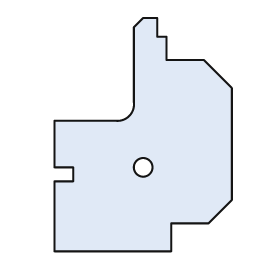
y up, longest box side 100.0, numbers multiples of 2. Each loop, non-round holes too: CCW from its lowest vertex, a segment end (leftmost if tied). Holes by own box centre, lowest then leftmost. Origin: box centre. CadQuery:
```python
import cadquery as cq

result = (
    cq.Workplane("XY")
    .moveTo(-38.0, -50.0)
    .lineTo(12.0, -50.0)
    .lineTo(12.0, -38.0)
    .lineTo(28.0, -38.0)
    .lineTo(38.0, -28.0)
    .lineTo(38.0, 20.0)
    .lineTo(26.0, 32.0)
    .lineTo(10.0, 32.0)
    .lineTo(10.0, 42.0)
    .lineTo(6.0, 42.0)
    .lineTo(6.0, 50.0)
    .lineTo(0.0, 50.0)
    .lineTo(-4.0, 46.0)
    .lineTo(-4.0, 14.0)
    .threePointArc((-6.0, 8.0), (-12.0, 6.0))
    .lineTo(-38.0, 6.0)
    .lineTo(-38.0, -14.0)
    .lineTo(-30.0, -14.0)
    .lineTo(-30.0, -20.0)
    .lineTo(-38.0, -20.0)
    .close()
    .moveTo(0.0, -14.0)
    .circle(4.0)
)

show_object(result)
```